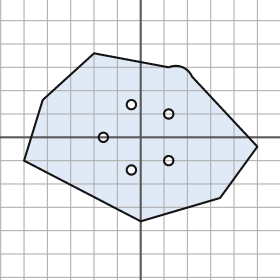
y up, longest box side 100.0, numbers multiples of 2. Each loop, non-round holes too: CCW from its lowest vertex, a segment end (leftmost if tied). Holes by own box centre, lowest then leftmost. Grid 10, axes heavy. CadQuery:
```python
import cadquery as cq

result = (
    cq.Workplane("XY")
    .moveTo(0.0, -36.0)
    .lineTo(34.0, -26.0)
    .lineTo(50.0, -4.0)
    .lineTo(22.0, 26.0)
    .threePointArc((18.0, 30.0), (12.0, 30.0))
    .lineTo(-20.0, 36.0)
    .lineTo(-42.0, 16.0)
    .lineTo(-50.0, -10.0)
    .close()
    .moveTo(-4.0, -14.0)
    .circle(2.0)
    .moveTo(12.0, -10.0)
    .circle(2.0)
    .moveTo(-16.0, 0.0)
    .circle(2.0)
    .moveTo(12.0, 10.0)
    .circle(2.0)
    .moveTo(-4.0, 14.0)
    .circle(2.0)
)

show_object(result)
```